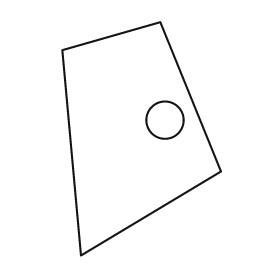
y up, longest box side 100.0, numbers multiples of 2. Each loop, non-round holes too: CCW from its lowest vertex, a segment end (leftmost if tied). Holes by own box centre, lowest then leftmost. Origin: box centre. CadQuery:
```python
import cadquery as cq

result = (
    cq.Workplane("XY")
    .moveTo(-26.0, -50.0)
    .lineTo(34.0, -14.0)
    .lineTo(8.0, 50.0)
    .lineTo(-34.0, 38.0)
    .close()
    .moveTo(10.0, 8.0)
    .circle(8.0)
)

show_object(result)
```